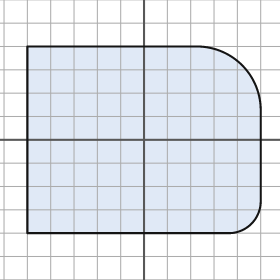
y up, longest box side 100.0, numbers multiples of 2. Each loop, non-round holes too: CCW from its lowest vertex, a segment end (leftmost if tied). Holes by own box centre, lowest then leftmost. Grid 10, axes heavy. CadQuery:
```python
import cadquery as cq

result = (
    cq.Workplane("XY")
    .moveTo(-50.0, -40.0)
    .lineTo(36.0, -40.0)
    .threePointArc((46.0, -36.0), (50.0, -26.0))
    .lineTo(50.0, 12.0)
    .threePointArc((42.0, 32.0), (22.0, 40.0))
    .lineTo(-50.0, 40.0)
    .close()
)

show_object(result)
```